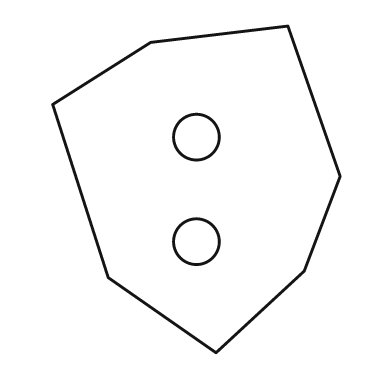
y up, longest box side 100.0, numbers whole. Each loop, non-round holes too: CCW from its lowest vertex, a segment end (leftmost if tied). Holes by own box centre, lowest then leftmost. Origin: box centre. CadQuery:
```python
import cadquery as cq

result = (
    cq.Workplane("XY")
    .moveTo(6.0, -50.0)
    .lineTo(33.0, -25.0)
    .lineTo(44.0, 4.0)
    .lineTo(28.0, 50.0)
    .lineTo(-14.0, 45.0)
    .lineTo(-44.0, 26.0)
    .lineTo(-27.0, -27.0)
    .close()
    .moveTo(0.0, -16.0)
    .circle(7.0)
    .moveTo(0.0, 16.0)
    .circle(7.0)
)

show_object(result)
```